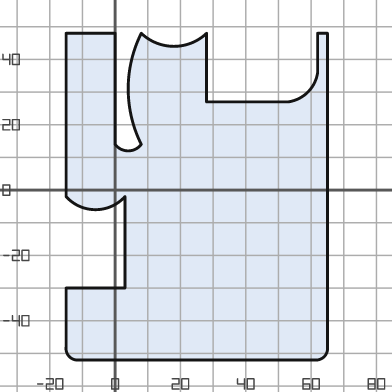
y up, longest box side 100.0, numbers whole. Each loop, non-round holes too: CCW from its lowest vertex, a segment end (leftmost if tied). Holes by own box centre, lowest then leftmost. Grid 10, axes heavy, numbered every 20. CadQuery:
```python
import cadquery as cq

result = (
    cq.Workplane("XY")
    .moveTo(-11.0, -52.0)
    .lineTo(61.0, -52.0)
    .threePointArc((64.0, -51.0), (65.0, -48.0))
    .lineTo(65.0, 48.0)
    .lineTo(62.0, 48.0)
    .lineTo(62.0, 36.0)
    .threePointArc((59.0, 30.0), (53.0, 27.0))
    .lineTo(28.0, 27.0)
    .lineTo(28.0, 48.0)
    .threePointArc((18.0, 44.0), (8.0, 48.0))
    .threePointArc((4.0, 31.0), (8.0, 14.0))
    .threePointArc((4.0, 12.0), (0.0, 14.0))
    .lineTo(0.0, 48.0)
    .lineTo(-15.0, 48.0)
    .lineTo(-15.0, -2.0)
    .threePointArc((-6.0, -6.0), (3.0, -2.0))
    .lineTo(3.0, -30.0)
    .lineTo(-15.0, -30.0)
    .lineTo(-15.0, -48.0)
    .threePointArc((-14.0, -51.0), (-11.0, -52.0))
    .close()
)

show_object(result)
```